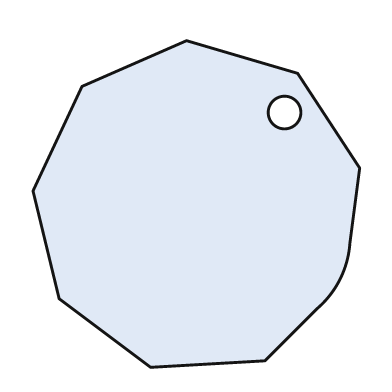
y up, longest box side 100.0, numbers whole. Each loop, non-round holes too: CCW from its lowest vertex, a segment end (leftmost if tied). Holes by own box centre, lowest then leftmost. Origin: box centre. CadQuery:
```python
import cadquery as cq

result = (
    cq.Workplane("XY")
    .moveTo(-14.0, -50.0)
    .lineTo(21.0, -48.0)
    .lineTo(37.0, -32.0)
    .threePointArc((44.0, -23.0), (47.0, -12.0))
    .lineTo(50.0, 11.0)
    .lineTo(31.0, 40.0)
    .lineTo(-3.0, 50.0)
    .lineTo(-35.0, 36.0)
    .lineTo(-50.0, 4.0)
    .lineTo(-42.0, -29.0)
    .close()
    .moveTo(27.0, 28.0)
    .circle(5.0)
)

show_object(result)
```